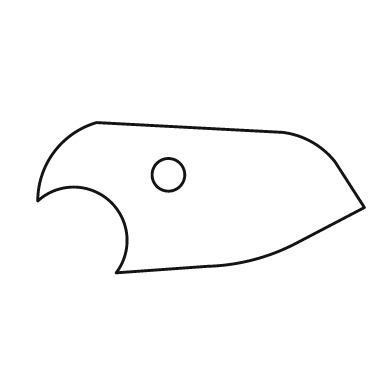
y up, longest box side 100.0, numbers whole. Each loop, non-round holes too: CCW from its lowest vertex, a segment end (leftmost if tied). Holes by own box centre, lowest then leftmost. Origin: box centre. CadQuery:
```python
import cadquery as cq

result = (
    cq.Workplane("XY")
    .moveTo(-26.0, -23.0)
    .lineTo(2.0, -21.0)
    .threePointArc((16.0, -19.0), (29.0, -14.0))
    .lineTo(50.0, -3.0)
    .lineTo(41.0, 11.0)
    .threePointArc((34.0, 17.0), (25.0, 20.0))
    .lineTo(-32.0, 23.0)
    .threePointArc((-45.0, 14.0), (-50.0, -1.0))
    .threePointArc((-28.0, -1.0), (-26.0, -23.0))
    .close()
    .moveTo(-10.0, 7.0)
    .circle(5.0)
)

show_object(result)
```